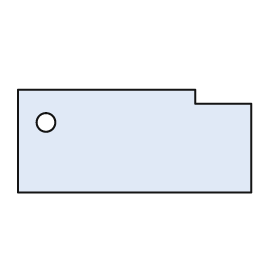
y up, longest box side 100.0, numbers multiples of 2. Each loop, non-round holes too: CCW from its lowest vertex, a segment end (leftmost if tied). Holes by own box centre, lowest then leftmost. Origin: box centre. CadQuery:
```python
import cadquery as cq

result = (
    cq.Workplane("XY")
    .moveTo(-50.0, -22.0)
    .lineTo(50.0, -22.0)
    .lineTo(50.0, 16.0)
    .lineTo(26.0, 16.0)
    .lineTo(26.0, 22.0)
    .lineTo(-50.0, 22.0)
    .close()
    .moveTo(-38.0, 8.0)
    .circle(4.0)
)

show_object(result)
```